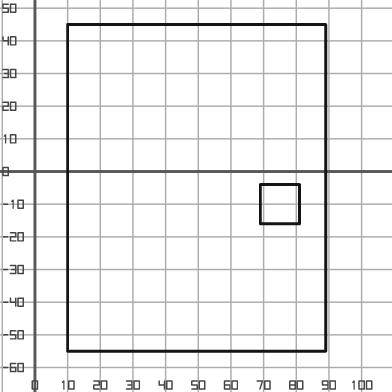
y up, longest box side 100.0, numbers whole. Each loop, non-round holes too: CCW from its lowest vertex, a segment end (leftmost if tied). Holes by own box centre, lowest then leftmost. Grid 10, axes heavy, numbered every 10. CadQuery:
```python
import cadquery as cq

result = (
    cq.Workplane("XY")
    .moveTo(10.0, -55.0)
    .lineTo(89.0, -55.0)
    .lineTo(89.0, 45.0)
    .lineTo(10.0, 45.0)
    .close()
    .moveTo(69.0, -16.0)
    .lineTo(81.0, -16.0)
    .lineTo(81.0, -4.0)
    .lineTo(69.0, -4.0)
    .close()
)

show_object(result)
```